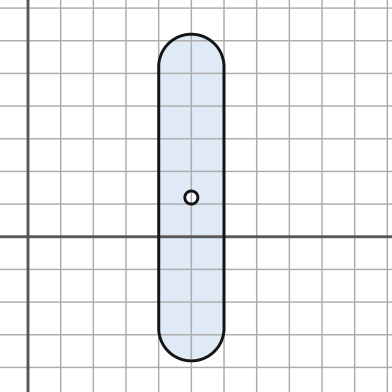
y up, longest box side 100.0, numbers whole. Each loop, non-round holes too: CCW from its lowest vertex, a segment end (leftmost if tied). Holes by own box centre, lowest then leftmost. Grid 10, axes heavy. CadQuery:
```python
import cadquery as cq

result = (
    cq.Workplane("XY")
    .moveTo(40.0, -28.0)
    .threePointArc((50.0, -38.0), (60.0, -28.0))
    .lineTo(60.0, 52.0)
    .threePointArc((50.0, 62.0), (40.0, 52.0))
    .close()
    .moveTo(50.0, 12.0)
    .circle(2.0)
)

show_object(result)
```